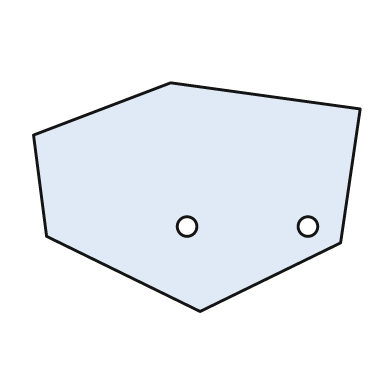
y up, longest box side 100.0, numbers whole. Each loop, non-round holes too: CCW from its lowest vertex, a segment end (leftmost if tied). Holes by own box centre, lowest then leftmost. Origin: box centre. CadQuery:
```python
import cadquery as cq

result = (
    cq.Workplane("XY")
    .moveTo(1.0, -35.0)
    .lineTo(44.0, -14.0)
    .lineTo(50.0, 27.0)
    .lineTo(-8.0, 35.0)
    .lineTo(-50.0, 19.0)
    .lineTo(-46.0, -12.0)
    .close()
    .moveTo(-3.0, -9.0)
    .circle(3.0)
    .moveTo(34.0, -9.0)
    .circle(3.0)
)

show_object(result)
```